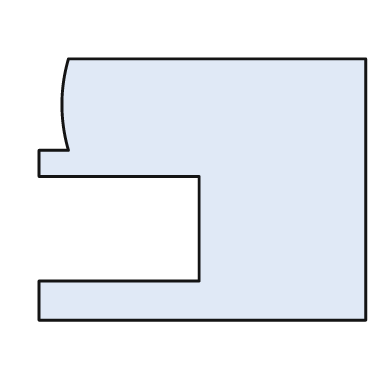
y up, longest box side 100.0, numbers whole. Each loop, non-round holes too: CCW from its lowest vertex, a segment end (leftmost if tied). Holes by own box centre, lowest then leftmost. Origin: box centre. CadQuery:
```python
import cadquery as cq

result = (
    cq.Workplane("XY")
    .moveTo(-50.0, -40.0)
    .lineTo(50.0, -40.0)
    .lineTo(50.0, 40.0)
    .lineTo(-41.0, 40.0)
    .threePointArc((-43.0, 26.0), (-41.0, 12.0))
    .lineTo(-50.0, 12.0)
    .lineTo(-50.0, 4.0)
    .lineTo(-1.0, 4.0)
    .lineTo(-1.0, -28.0)
    .lineTo(-50.0, -28.0)
    .close()
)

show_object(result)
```